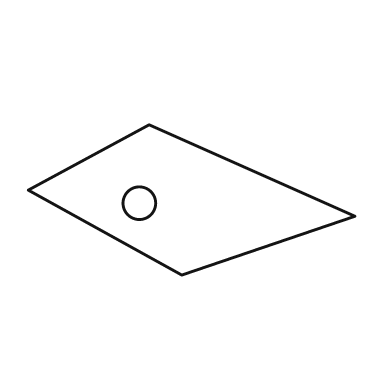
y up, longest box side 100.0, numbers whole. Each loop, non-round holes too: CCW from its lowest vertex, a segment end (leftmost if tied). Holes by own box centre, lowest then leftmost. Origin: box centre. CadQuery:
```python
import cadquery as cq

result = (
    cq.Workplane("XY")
    .moveTo(-3.0, -23.0)
    .lineTo(50.0, -5.0)
    .lineTo(-13.0, 23.0)
    .lineTo(-50.0, 3.0)
    .close()
    .moveTo(-16.0, -1.0)
    .circle(5.0)
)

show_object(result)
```